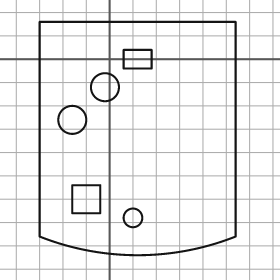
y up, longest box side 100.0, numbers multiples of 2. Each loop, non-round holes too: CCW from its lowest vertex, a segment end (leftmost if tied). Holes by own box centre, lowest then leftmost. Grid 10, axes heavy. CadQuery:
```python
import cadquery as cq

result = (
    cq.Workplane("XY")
    .moveTo(-30.0, -76.0)
    .threePointArc((12.0, -84.0), (54.0, -76.0))
    .lineTo(54.0, 16.0)
    .lineTo(-30.0, 16.0)
    .close()
    .moveTo(10.0, -68.0)
    .circle(4.0)
    .moveTo(-16.0, -66.0)
    .lineTo(-4.0, -66.0)
    .lineTo(-4.0, -54.0)
    .lineTo(-16.0, -54.0)
    .close()
    .moveTo(-16.0, -26.0)
    .circle(6.0)
    .moveTo(-2.0, -12.0)
    .circle(6.0)
    .moveTo(6.0, -4.0)
    .lineTo(18.0, -4.0)
    .lineTo(18.0, 4.0)
    .lineTo(6.0, 4.0)
    .close()
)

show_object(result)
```